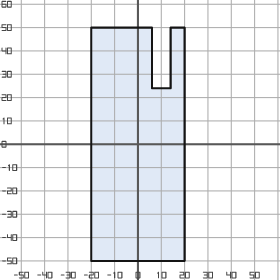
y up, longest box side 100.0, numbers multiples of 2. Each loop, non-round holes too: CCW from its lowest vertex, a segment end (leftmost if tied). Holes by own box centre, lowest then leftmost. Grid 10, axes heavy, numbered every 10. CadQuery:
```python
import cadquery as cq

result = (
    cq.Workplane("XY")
    .moveTo(-20.0, -50.0)
    .lineTo(20.0, -50.0)
    .lineTo(20.0, 50.0)
    .lineTo(14.0, 50.0)
    .lineTo(14.0, 24.0)
    .lineTo(6.0, 24.0)
    .lineTo(6.0, 50.0)
    .lineTo(-20.0, 50.0)
    .close()
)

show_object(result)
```